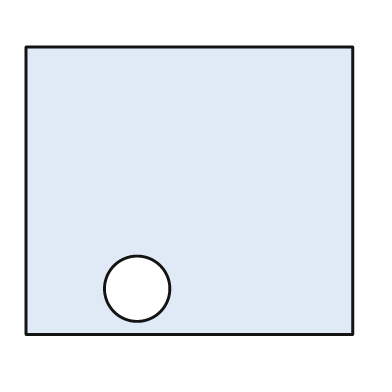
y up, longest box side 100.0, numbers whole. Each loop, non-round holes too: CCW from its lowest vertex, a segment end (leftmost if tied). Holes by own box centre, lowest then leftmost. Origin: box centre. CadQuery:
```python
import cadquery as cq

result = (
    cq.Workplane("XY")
    .moveTo(-50.0, -44.0)
    .lineTo(50.0, -44.0)
    .lineTo(50.0, 44.0)
    .lineTo(-50.0, 44.0)
    .close()
    .moveTo(-16.0, -30.0)
    .circle(10.0)
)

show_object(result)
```